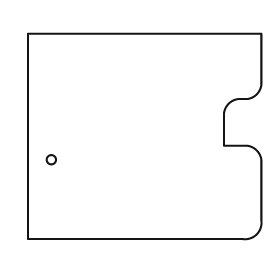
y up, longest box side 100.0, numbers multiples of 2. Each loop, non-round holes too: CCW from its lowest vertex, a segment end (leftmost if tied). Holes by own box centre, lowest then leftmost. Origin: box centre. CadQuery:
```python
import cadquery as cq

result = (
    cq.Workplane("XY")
    .moveTo(-50.0, -44.0)
    .lineTo(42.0, -44.0)
    .threePointArc((48.0, -42.0), (50.0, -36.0))
    .lineTo(50.0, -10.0)
    .threePointArc((48.0, -6.0), (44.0, -4.0))
    .lineTo(34.0, -4.0)
    .lineTo(34.0, 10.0)
    .threePointArc((36.0, 14.0), (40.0, 16.0))
    .lineTo(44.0, 16.0)
    .threePointArc((48.0, 18.0), (50.0, 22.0))
    .lineTo(50.0, 44.0)
    .lineTo(-50.0, 44.0)
    .close()
    .moveTo(-40.0, -10.0)
    .circle(2.0)
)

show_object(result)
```